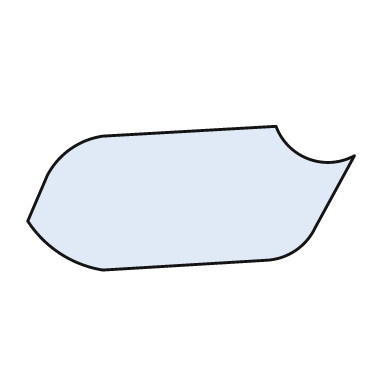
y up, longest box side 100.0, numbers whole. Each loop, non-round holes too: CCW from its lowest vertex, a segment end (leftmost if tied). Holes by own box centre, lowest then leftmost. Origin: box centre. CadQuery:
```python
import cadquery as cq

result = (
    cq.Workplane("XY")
    .moveTo(-27.0, -22.0)
    .lineTo(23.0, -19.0)
    .threePointArc((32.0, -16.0), (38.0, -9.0))
    .lineTo(50.0, 13.0)
    .threePointArc((36.0, 12.0), (26.0, 22.0))
    .lineTo(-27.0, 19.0)
    .threePointArc((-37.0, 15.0), (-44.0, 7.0))
    .lineTo(-50.0, -7.0)
    .threePointArc((-40.0, -17.0), (-27.0, -22.0))
    .close()
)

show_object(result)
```